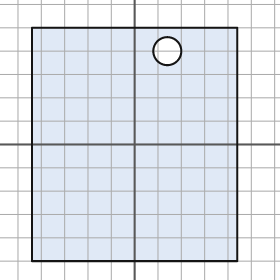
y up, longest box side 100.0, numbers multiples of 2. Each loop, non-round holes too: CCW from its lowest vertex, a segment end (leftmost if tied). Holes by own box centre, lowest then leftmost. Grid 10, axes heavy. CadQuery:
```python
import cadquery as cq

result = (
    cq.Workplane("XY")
    .moveTo(-44.0, -50.0)
    .lineTo(44.0, -50.0)
    .lineTo(44.0, 50.0)
    .lineTo(-44.0, 50.0)
    .close()
    .moveTo(14.0, 40.0)
    .circle(6.0)
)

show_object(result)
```